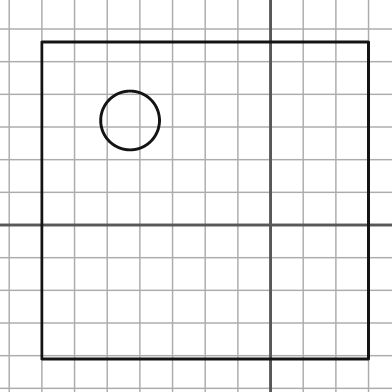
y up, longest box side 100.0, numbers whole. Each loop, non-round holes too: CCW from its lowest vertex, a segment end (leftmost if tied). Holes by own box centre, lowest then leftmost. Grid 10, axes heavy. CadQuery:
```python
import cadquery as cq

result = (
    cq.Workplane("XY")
    .moveTo(-70.0, -41.0)
    .lineTo(30.0, -41.0)
    .lineTo(30.0, 56.0)
    .lineTo(-70.0, 56.0)
    .close()
    .moveTo(-43.0, 32.0)
    .circle(9.0)
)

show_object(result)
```